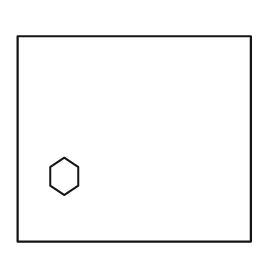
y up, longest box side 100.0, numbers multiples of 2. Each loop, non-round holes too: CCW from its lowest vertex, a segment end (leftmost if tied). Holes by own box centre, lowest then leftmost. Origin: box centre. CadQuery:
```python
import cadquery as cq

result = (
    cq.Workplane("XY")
    .moveTo(-50.0, -44.0)
    .lineTo(50.0, -44.0)
    .lineTo(50.0, 44.0)
    .lineTo(-50.0, 44.0)
    .close()
    .moveTo(-30.0, -24.0)
    .lineTo(-24.0, -20.0)
    .lineTo(-24.0, -12.0)
    .lineTo(-30.0, -8.0)
    .lineTo(-36.0, -12.0)
    .lineTo(-36.0, -20.0)
    .close()
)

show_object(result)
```